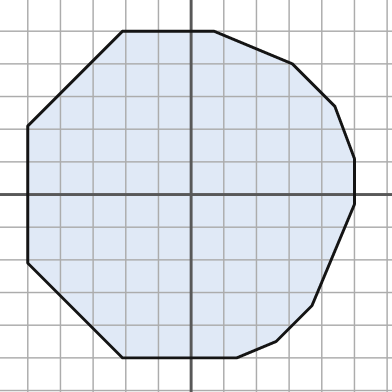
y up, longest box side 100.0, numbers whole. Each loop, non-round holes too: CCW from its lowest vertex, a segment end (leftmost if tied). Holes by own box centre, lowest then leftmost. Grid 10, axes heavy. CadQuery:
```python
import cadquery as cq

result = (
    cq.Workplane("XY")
    .moveTo(-21.0, -50.0)
    .lineTo(14.0, -50.0)
    .lineTo(26.0, -45.0)
    .lineTo(37.0, -34.0)
    .lineTo(50.0, -3.0)
    .lineTo(50.0, 11.0)
    .lineTo(44.0, 27.0)
    .lineTo(31.0, 40.0)
    .lineTo(7.0, 50.0)
    .lineTo(-21.0, 50.0)
    .lineTo(-50.0, 21.0)
    .lineTo(-50.0, -21.0)
    .close()
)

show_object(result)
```